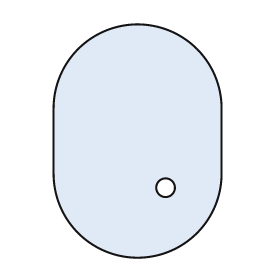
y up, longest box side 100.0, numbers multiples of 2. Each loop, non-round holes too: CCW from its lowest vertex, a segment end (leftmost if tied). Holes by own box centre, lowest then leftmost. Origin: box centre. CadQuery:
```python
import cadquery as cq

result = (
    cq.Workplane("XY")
    .moveTo(-36.0, -14.0)
    .threePointArc((0.0, -50.0), (36.0, -14.0))
    .lineTo(36.0, 14.0)
    .threePointArc((0.0, 50.0), (-36.0, 14.0))
    .close()
    .moveTo(12.0, -20.0)
    .circle(4.0)
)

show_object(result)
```